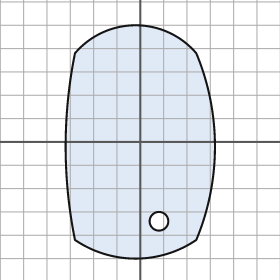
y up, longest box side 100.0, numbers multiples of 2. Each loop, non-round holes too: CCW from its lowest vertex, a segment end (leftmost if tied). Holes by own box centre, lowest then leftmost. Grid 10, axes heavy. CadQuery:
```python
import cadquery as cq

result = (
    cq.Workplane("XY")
    .moveTo(-28.0, -42.0)
    .threePointArc((-2.0, -50.0), (24.0, -42.0))
    .threePointArc((32.0, -2.0), (24.0, 38.0))
    .threePointArc((-2.0, 50.0), (-28.0, 38.0))
    .threePointArc((-32.0, -2.0), (-28.0, -42.0))
    .close()
    .moveTo(8.0, -34.0)
    .circle(4.0)
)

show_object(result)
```